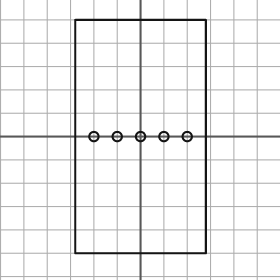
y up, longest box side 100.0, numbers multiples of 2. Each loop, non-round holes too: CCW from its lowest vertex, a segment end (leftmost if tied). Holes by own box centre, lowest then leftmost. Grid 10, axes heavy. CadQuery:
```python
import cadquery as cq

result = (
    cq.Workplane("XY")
    .moveTo(-28.0, -50.0)
    .lineTo(28.0, -50.0)
    .lineTo(28.0, 50.0)
    .lineTo(-28.0, 50.0)
    .close()
    .moveTo(-20.0, 0.0)
    .circle(2.0)
    .moveTo(-10.0, 0.0)
    .circle(2.0)
    .moveTo(0.0, 0.0)
    .circle(2.0)
    .moveTo(10.0, 0.0)
    .circle(2.0)
    .moveTo(20.0, 0.0)
    .circle(2.0)
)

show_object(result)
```